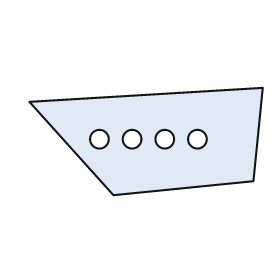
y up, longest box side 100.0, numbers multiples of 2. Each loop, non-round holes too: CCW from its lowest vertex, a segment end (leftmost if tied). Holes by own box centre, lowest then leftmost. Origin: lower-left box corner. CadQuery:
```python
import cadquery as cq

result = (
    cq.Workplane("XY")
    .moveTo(36.0, 0.0)
    .lineTo(96.0, 6.0)
    .lineTo(100.0, 46.0)
    .lineTo(0.0, 40.0)
    .close()
    .moveTo(30.0, 24.0)
    .circle(4.0)
    .moveTo(44.0, 24.0)
    .circle(4.0)
    .moveTo(58.0, 24.0)
    .circle(4.0)
    .moveTo(72.0, 24.0)
    .circle(4.0)
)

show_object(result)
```